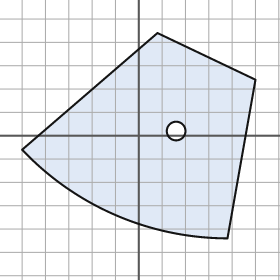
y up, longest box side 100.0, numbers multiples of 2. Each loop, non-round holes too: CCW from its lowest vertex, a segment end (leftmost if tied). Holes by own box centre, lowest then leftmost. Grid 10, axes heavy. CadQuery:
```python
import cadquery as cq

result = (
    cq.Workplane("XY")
    .moveTo(38.0, -44.0)
    .lineTo(50.0, 24.0)
    .lineTo(8.0, 44.0)
    .lineTo(-50.0, -6.0)
    .threePointArc((-10.0, -34.0), (38.0, -44.0))
    .close()
    .moveTo(16.0, 2.0)
    .circle(4.0)
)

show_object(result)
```